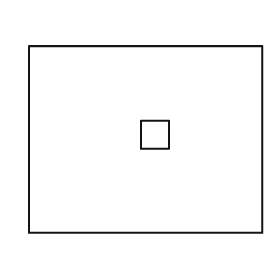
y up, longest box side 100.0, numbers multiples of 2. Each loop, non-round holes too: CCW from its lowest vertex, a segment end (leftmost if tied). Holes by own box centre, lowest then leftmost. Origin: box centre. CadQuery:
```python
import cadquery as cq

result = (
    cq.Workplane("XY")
    .moveTo(-50.0, -40.0)
    .lineTo(50.0, -40.0)
    .lineTo(50.0, 40.0)
    .lineTo(-50.0, 40.0)
    .close()
    .moveTo(-2.0, -4.0)
    .lineTo(10.0, -4.0)
    .lineTo(10.0, 8.0)
    .lineTo(-2.0, 8.0)
    .close()
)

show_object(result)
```